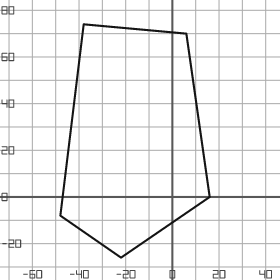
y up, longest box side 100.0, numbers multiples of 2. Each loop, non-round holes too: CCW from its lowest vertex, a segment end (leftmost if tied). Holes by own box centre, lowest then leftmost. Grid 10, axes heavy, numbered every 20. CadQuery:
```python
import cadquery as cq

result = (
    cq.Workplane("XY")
    .moveTo(-22.0, -26.0)
    .lineTo(16.0, 0.0)
    .lineTo(6.0, 70.0)
    .lineTo(-38.0, 74.0)
    .lineTo(-48.0, -8.0)
    .close()
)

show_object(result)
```